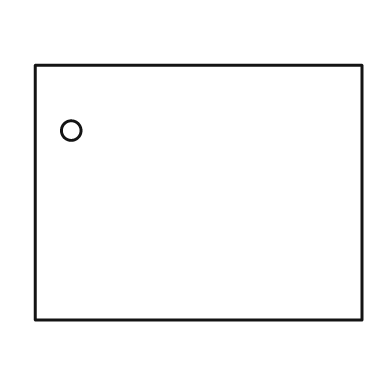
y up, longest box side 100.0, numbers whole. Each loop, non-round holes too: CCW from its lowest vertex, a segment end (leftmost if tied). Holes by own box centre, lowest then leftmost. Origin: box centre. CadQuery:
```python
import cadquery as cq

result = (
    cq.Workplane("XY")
    .moveTo(-50.0, -39.0)
    .lineTo(50.0, -39.0)
    .lineTo(50.0, 39.0)
    .lineTo(-50.0, 39.0)
    .close()
    .moveTo(-39.0, 19.0)
    .circle(3.0)
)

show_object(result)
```